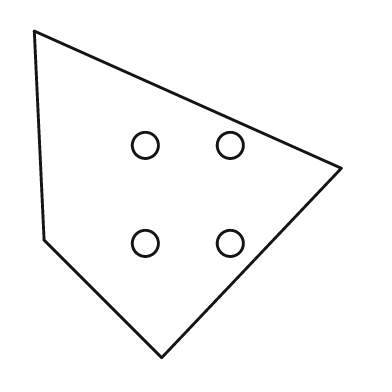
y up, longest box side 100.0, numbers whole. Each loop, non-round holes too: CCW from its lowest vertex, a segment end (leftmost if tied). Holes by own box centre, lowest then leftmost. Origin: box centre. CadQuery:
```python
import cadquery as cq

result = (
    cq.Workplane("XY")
    .moveTo(-8.0, -50.0)
    .lineTo(47.0, 8.0)
    .lineTo(-47.0, 50.0)
    .lineTo(-44.0, -14.0)
    .close()
    .moveTo(-13.0, -15.0)
    .circle(4.0)
    .moveTo(13.0, -15.0)
    .circle(4.0)
    .moveTo(-13.0, 15.0)
    .circle(4.0)
    .moveTo(13.0, 15.0)
    .circle(4.0)
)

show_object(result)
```